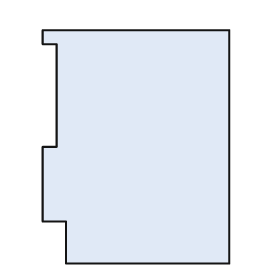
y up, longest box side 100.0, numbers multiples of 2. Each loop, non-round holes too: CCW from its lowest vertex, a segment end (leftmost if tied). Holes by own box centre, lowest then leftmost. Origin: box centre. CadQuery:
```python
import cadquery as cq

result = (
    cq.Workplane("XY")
    .moveTo(-30.0, -50.0)
    .lineTo(40.0, -50.0)
    .lineTo(40.0, 50.0)
    .lineTo(-40.0, 50.0)
    .lineTo(-40.0, 44.0)
    .lineTo(-34.0, 44.0)
    .lineTo(-34.0, 0.0)
    .lineTo(-40.0, 0.0)
    .lineTo(-40.0, -32.0)
    .lineTo(-30.0, -32.0)
    .close()
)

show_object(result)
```